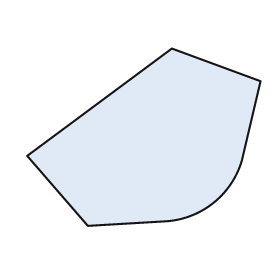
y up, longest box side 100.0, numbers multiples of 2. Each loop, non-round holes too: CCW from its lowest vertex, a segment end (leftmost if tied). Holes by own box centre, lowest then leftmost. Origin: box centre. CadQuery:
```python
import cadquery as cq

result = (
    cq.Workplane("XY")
    .moveTo(-24.0, -38.0)
    .lineTo(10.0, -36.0)
    .threePointArc((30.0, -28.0), (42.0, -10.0))
    .lineTo(50.0, 24.0)
    .lineTo(12.0, 38.0)
    .lineTo(-50.0, -8.0)
    .close()
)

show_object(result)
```